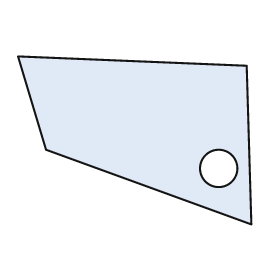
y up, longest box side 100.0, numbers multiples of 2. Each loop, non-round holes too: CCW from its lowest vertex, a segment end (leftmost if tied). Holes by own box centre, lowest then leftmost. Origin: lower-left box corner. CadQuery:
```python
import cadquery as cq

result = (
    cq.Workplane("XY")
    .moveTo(100.0, 0.0)
    .lineTo(98.0, 68.0)
    .lineTo(0.0, 72.0)
    .lineTo(12.0, 32.0)
    .close()
    .moveTo(86.0, 24.0)
    .circle(8.0)
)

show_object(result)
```